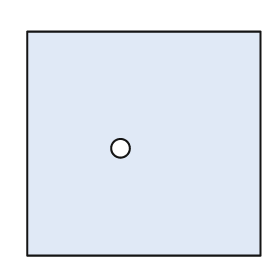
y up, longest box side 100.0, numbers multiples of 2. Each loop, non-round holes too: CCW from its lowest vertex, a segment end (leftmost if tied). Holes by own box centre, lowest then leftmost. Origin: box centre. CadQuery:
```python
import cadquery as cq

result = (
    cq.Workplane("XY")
    .moveTo(-50.0, -48.0)
    .lineTo(50.0, -48.0)
    .lineTo(50.0, 48.0)
    .lineTo(-50.0, 48.0)
    .close()
    .moveTo(-10.0, -2.0)
    .circle(4.0)
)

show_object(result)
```